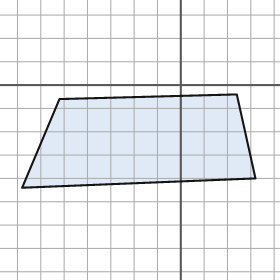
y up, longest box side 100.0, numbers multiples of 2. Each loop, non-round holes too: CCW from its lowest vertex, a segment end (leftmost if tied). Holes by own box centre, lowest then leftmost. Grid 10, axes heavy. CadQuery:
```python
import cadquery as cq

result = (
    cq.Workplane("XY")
    .moveTo(-68.0, -44.0)
    .lineTo(32.0, -40.0)
    .lineTo(24.0, -4.0)
    .lineTo(-52.0, -6.0)
    .close()
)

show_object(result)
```